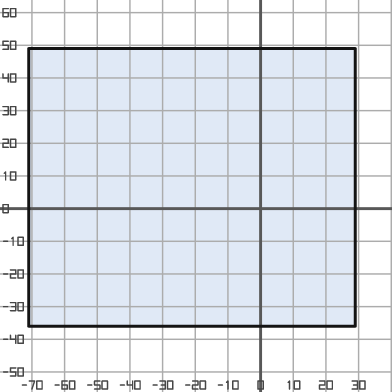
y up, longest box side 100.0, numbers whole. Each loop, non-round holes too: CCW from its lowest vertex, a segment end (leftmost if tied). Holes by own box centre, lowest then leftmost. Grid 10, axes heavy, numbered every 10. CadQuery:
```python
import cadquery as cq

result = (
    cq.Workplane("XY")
    .moveTo(-71.0, -36.0)
    .lineTo(29.0, -36.0)
    .lineTo(29.0, 49.0)
    .lineTo(-71.0, 49.0)
    .close()
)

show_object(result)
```